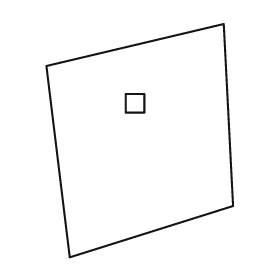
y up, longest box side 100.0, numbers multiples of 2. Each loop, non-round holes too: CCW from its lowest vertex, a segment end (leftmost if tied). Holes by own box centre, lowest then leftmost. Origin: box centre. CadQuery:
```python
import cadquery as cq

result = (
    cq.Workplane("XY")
    .moveTo(-30.0, -50.0)
    .lineTo(40.0, -28.0)
    .lineTo(36.0, 50.0)
    .lineTo(-40.0, 32.0)
    .close()
    .moveTo(-6.0, 12.0)
    .lineTo(2.0, 12.0)
    .lineTo(2.0, 20.0)
    .lineTo(-6.0, 20.0)
    .close()
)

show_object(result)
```